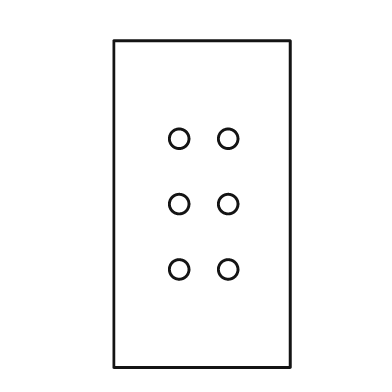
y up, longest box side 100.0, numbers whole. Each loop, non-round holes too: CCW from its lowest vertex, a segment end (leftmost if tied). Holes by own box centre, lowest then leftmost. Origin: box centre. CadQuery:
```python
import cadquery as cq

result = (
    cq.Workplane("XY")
    .moveTo(-27.0, -50.0)
    .lineTo(27.0, -50.0)
    .lineTo(27.0, 50.0)
    .lineTo(-27.0, 50.0)
    .close()
    .moveTo(-7.0, -20.0)
    .circle(3.0)
    .moveTo(8.0, -20.0)
    .circle(3.0)
    .moveTo(-7.0, 0.0)
    .circle(3.0)
    .moveTo(8.0, 0.0)
    .circle(3.0)
    .moveTo(-7.0, 20.0)
    .circle(3.0)
    .moveTo(8.0, 20.0)
    .circle(3.0)
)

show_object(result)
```